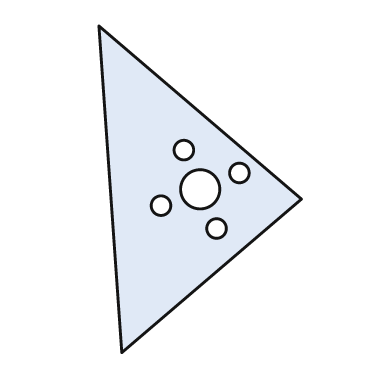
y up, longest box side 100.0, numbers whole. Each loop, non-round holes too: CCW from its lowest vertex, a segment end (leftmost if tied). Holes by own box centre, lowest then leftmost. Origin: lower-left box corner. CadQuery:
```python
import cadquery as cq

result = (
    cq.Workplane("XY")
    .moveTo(7.0, 0.0)
    .lineTo(62.0, 47.0)
    .lineTo(0.0, 100.0)
    .close()
    .moveTo(36.0, 38.0)
    .circle(3.0)
    .moveTo(19.0, 45.0)
    .circle(3.0)
    .moveTo(31.0, 50.0)
    .circle(6.0)
    .moveTo(43.0, 55.0)
    .circle(3.0)
    .moveTo(26.0, 62.0)
    .circle(3.0)
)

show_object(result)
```